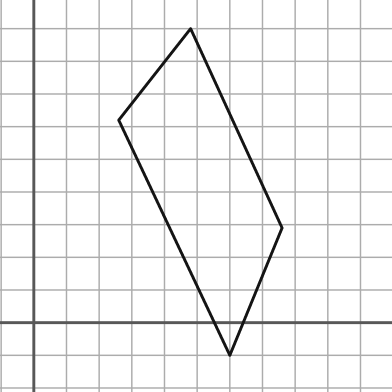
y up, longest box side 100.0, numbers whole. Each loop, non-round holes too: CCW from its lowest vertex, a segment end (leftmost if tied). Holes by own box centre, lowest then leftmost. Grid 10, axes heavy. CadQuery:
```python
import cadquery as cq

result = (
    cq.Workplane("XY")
    .moveTo(60.0, -10.0)
    .lineTo(76.0, 29.0)
    .lineTo(48.0, 90.0)
    .lineTo(26.0, 62.0)
    .close()
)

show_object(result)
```